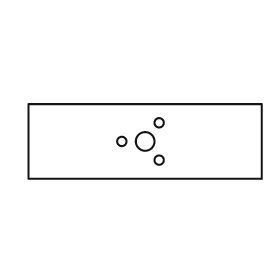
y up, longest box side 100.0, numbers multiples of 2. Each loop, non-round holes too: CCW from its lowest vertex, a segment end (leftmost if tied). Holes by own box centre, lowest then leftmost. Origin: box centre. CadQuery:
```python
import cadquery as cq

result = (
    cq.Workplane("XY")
    .moveTo(-50.0, -16.0)
    .lineTo(50.0, -16.0)
    .lineTo(50.0, 16.0)
    .lineTo(-50.0, 16.0)
    .close()
    .moveTo(6.0, -8.0)
    .circle(2.0)
    .moveTo(-10.0, 0.0)
    .circle(2.0)
    .moveTo(0.0, 0.0)
    .circle(4.0)
    .moveTo(6.0, 8.0)
    .circle(2.0)
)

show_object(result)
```